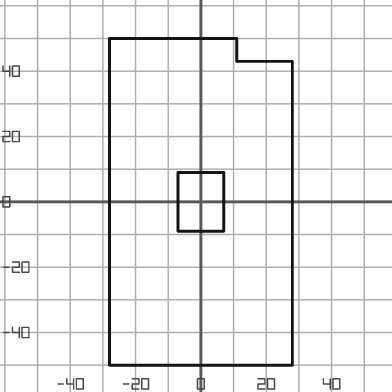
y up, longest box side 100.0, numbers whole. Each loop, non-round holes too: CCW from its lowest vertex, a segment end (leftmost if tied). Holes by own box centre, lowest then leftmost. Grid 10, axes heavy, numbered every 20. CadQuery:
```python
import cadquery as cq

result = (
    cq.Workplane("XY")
    .moveTo(-28.0, -50.0)
    .lineTo(28.0, -50.0)
    .lineTo(28.0, 43.0)
    .lineTo(11.0, 43.0)
    .lineTo(11.0, 50.0)
    .lineTo(-28.0, 50.0)
    .close()
    .moveTo(-7.0, -9.0)
    .lineTo(7.0, -9.0)
    .lineTo(7.0, 9.0)
    .lineTo(-7.0, 9.0)
    .close()
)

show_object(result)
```